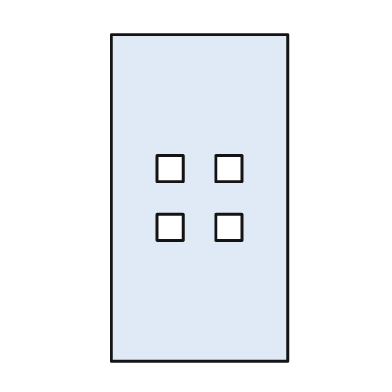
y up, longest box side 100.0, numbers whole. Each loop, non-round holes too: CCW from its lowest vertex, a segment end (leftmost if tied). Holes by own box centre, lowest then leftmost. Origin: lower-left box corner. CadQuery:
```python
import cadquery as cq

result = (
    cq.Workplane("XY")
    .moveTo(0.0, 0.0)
    .lineTo(54.0, 0.0)
    .lineTo(54.0, 100.0)
    .lineTo(0.0, 100.0)
    .close()
    .moveTo(14.0, 37.0)
    .lineTo(22.0, 37.0)
    .lineTo(22.0, 45.0)
    .lineTo(14.0, 45.0)
    .close()
    .moveTo(32.0, 37.0)
    .lineTo(40.0, 37.0)
    .lineTo(40.0, 45.0)
    .lineTo(32.0, 45.0)
    .close()
    .moveTo(14.0, 55.0)
    .lineTo(22.0, 55.0)
    .lineTo(22.0, 63.0)
    .lineTo(14.0, 63.0)
    .close()
    .moveTo(32.0, 55.0)
    .lineTo(40.0, 55.0)
    .lineTo(40.0, 63.0)
    .lineTo(32.0, 63.0)
    .close()
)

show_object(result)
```